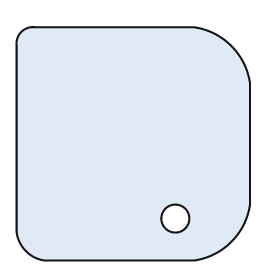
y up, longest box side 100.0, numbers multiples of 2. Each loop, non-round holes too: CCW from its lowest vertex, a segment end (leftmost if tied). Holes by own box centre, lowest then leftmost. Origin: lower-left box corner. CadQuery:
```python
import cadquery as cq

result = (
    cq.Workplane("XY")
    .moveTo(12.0, 0.0)
    .lineTo(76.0, 0.0)
    .threePointArc((92.0, 8.0), (100.0, 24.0))
    .lineTo(100.0, 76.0)
    .threePointArc((92.0, 92.0), (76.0, 100.0))
    .lineTo(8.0, 100.0)
    .threePointArc((2.0, 98.0), (0.0, 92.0))
    .lineTo(0.0, 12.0)
    .threePointArc((4.0, 4.0), (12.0, 0.0))
    .close()
    .moveTo(68.0, 18.0)
    .circle(6.0)
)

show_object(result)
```